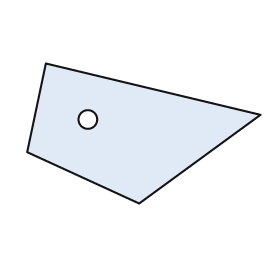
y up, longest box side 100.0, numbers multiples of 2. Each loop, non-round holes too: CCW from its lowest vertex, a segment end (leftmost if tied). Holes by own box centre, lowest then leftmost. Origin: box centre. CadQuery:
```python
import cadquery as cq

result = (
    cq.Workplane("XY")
    .moveTo(-2.0, -30.0)
    .lineTo(50.0, 8.0)
    .lineTo(-42.0, 30.0)
    .lineTo(-50.0, -8.0)
    .close()
    .moveTo(-24.0, 6.0)
    .circle(4.0)
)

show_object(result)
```